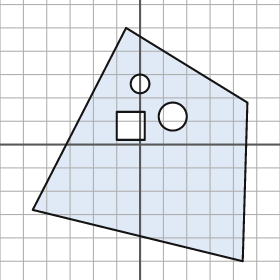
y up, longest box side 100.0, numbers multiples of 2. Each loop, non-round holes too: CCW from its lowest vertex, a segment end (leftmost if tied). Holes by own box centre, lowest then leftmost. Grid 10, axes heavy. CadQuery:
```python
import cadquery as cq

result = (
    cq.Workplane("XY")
    .moveTo(44.0, -50.0)
    .lineTo(46.0, 18.0)
    .lineTo(-6.0, 50.0)
    .lineTo(-46.0, -28.0)
    .close()
    .moveTo(-10.0, 2.0)
    .lineTo(2.0, 2.0)
    .lineTo(2.0, 14.0)
    .lineTo(-10.0, 14.0)
    .close()
    .moveTo(14.0, 12.0)
    .circle(6.0)
    .moveTo(0.0, 26.0)
    .circle(4.0)
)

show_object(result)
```